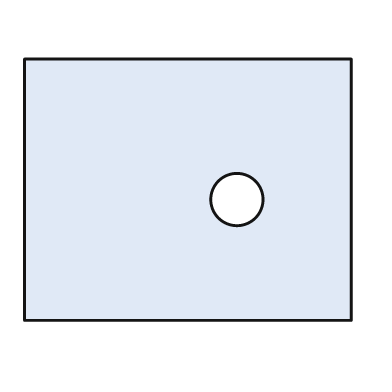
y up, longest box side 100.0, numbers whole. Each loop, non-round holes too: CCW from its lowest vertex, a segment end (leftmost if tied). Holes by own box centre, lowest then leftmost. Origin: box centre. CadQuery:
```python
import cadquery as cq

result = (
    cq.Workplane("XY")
    .moveTo(-50.0, -40.0)
    .lineTo(50.0, -40.0)
    .lineTo(50.0, 40.0)
    .lineTo(-50.0, 40.0)
    .close()
    .moveTo(15.0, -3.0)
    .circle(8.0)
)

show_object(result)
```